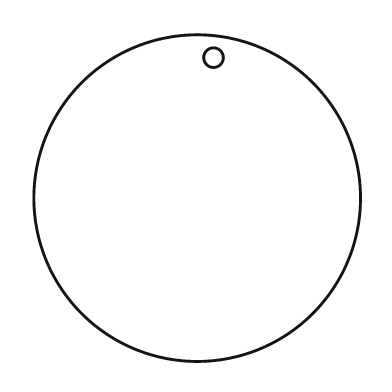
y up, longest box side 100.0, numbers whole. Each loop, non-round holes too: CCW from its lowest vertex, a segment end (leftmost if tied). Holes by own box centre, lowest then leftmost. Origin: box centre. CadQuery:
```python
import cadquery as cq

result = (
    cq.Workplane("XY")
    .moveTo(0.0, 0.0)
    .circle(50.0)
    .moveTo(5.0, 43.0)
    .circle(3.0)
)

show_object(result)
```